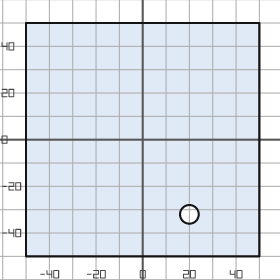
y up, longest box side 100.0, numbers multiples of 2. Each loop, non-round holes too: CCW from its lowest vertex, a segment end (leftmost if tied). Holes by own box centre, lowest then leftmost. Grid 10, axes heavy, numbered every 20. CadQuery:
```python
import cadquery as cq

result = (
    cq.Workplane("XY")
    .moveTo(-50.0, -50.0)
    .lineTo(50.0, -50.0)
    .lineTo(50.0, 50.0)
    .lineTo(-50.0, 50.0)
    .close()
    .moveTo(20.0, -32.0)
    .circle(4.0)
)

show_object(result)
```